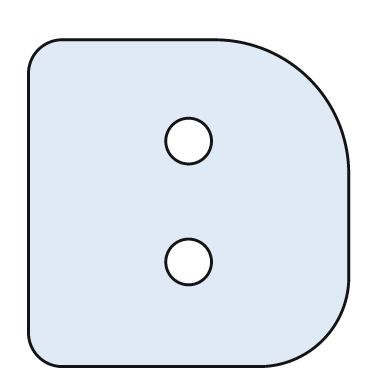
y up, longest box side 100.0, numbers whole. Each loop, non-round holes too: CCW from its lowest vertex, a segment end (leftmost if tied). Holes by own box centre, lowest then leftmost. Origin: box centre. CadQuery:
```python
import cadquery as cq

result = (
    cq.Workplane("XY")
    .moveTo(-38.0, -50.0)
    .lineTo(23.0, -50.0)
    .threePointArc((41.0, -42.0), (49.0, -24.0))
    .lineTo(49.0, 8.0)
    .threePointArc((37.0, 38.0), (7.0, 50.0))
    .lineTo(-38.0, 50.0)
    .threePointArc((-46.0, 47.0), (-49.0, 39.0))
    .lineTo(-49.0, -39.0)
    .threePointArc((-46.0, -47.0), (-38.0, -50.0))
    .close()
    .moveTo(0.0, -18.0)
    .circle(7.0)
    .moveTo(0.0, 19.0)
    .circle(7.0)
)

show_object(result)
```